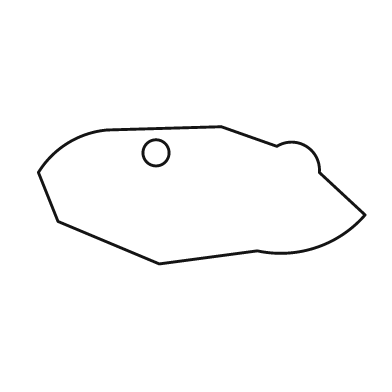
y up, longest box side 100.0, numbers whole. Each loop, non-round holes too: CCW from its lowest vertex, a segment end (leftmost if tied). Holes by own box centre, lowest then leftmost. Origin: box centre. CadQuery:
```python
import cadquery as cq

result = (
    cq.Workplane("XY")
    .moveTo(-13.0, -21.0)
    .lineTo(17.0, -17.0)
    .threePointArc((35.0, -16.0), (50.0, -6.0))
    .lineTo(36.0, 7.0)
    .threePointArc((32.0, 15.0), (23.0, 15.0))
    .lineTo(6.0, 21.0)
    .lineTo(-29.0, 20.0)
    .threePointArc((-41.0, 16.0), (-50.0, 7.0))
    .lineTo(-44.0, -8.0)
    .close()
    .moveTo(-14.0, 13.0)
    .circle(4.0)
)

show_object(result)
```